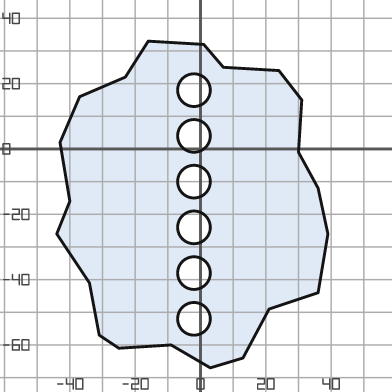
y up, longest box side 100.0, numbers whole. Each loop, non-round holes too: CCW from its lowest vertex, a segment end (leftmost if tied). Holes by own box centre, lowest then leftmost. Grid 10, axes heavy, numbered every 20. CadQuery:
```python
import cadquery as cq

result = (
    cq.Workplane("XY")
    .moveTo(3.0, -67.0)
    .lineTo(13.0, -64.0)
    .lineTo(21.0, -49.0)
    .lineTo(36.0, -44.0)
    .lineTo(39.0, -26.0)
    .lineTo(36.0, -12.0)
    .lineTo(30.0, -1.0)
    .lineTo(31.0, 15.0)
    .lineTo(24.0, 24.0)
    .lineTo(7.0, 25.0)
    .lineTo(1.0, 32.0)
    .lineTo(-16.0, 33.0)
    .lineTo(-23.0, 22.0)
    .lineTo(-37.0, 16.0)
    .lineTo(-43.0, 2.0)
    .lineTo(-40.0, -16.0)
    .lineTo(-44.0, -26.0)
    .lineTo(-34.0, -41.0)
    .lineTo(-31.0, -57.0)
    .lineTo(-25.0, -61.0)
    .lineTo(-9.0, -60.0)
    .close()
    .moveTo(-2.0, -52.0)
    .circle(5.0)
    .moveTo(-2.0, -38.0)
    .circle(5.0)
    .moveTo(-2.0, -24.0)
    .circle(5.0)
    .moveTo(-2.0, -10.0)
    .circle(5.0)
    .moveTo(-2.0, 4.0)
    .circle(5.0)
    .moveTo(-2.0, 18.0)
    .circle(5.0)
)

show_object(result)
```